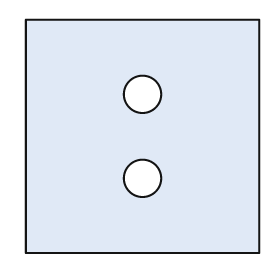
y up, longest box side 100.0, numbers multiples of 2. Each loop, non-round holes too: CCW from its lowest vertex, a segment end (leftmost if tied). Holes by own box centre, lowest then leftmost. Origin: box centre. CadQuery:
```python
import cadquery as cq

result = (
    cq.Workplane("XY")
    .moveTo(-50.0, -50.0)
    .lineTo(50.0, -50.0)
    .lineTo(50.0, 50.0)
    .lineTo(-50.0, 50.0)
    .close()
    .moveTo(0.0, -18.0)
    .circle(8.0)
    .moveTo(0.0, 18.0)
    .circle(8.0)
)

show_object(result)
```